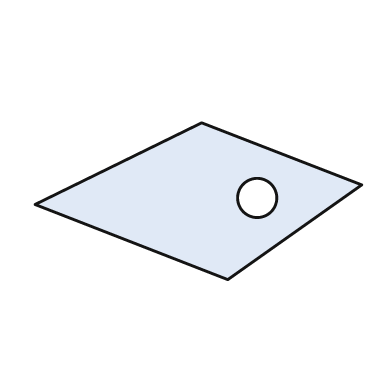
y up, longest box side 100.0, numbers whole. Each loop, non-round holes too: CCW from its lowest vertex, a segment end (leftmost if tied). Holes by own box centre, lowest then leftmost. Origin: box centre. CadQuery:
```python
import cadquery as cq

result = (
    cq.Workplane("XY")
    .moveTo(9.0, -24.0)
    .lineTo(50.0, 5.0)
    .lineTo(1.0, 24.0)
    .lineTo(-50.0, -1.0)
    .close()
    .moveTo(18.0, 1.0)
    .circle(6.0)
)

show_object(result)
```